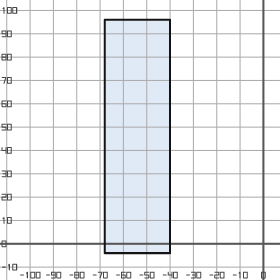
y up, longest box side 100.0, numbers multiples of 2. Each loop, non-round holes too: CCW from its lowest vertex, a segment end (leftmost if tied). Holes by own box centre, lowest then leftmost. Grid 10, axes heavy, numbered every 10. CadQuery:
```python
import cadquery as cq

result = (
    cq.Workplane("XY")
    .moveTo(-68.0, -4.0)
    .lineTo(-40.0, -4.0)
    .lineTo(-40.0, 96.0)
    .lineTo(-68.0, 96.0)
    .close()
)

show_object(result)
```